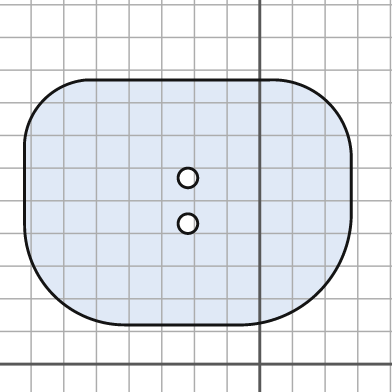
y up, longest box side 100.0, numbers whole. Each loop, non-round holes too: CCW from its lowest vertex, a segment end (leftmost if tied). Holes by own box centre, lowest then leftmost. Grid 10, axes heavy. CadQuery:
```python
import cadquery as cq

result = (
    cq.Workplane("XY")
    .moveTo(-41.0, 12.0)
    .lineTo(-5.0, 12.0)
    .threePointArc((18.0, 22.0), (28.0, 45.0))
    .lineTo(28.0, 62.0)
    .threePointArc((21.0, 80.0), (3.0, 87.0))
    .lineTo(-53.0, 87.0)
    .threePointArc((-66.0, 81.0), (-72.0, 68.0))
    .lineTo(-72.0, 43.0)
    .threePointArc((-63.0, 21.0), (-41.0, 12.0))
    .close()
    .moveTo(-22.0, 43.0)
    .circle(3.0)
    .moveTo(-22.0, 57.0)
    .circle(3.0)
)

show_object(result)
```